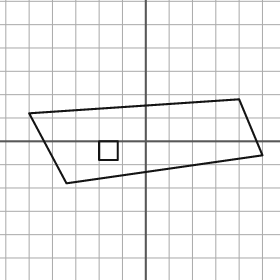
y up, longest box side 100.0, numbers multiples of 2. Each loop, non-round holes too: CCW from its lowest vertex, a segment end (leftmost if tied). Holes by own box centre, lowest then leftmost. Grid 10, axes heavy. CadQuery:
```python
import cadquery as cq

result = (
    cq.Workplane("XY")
    .moveTo(-34.0, -18.0)
    .lineTo(50.0, -6.0)
    .lineTo(40.0, 18.0)
    .lineTo(-50.0, 12.0)
    .close()
    .moveTo(-20.0, -8.0)
    .lineTo(-12.0, -8.0)
    .lineTo(-12.0, 0.0)
    .lineTo(-20.0, 0.0)
    .close()
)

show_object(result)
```